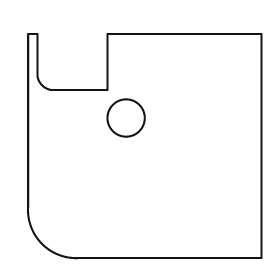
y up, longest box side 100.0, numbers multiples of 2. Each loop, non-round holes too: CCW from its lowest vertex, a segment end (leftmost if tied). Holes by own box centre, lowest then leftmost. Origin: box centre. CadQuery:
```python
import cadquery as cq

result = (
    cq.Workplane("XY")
    .moveTo(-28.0, -48.0)
    .lineTo(50.0, -48.0)
    .lineTo(50.0, 48.0)
    .lineTo(-16.0, 48.0)
    .lineTo(-16.0, 24.0)
    .lineTo(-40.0, 24.0)
    .threePointArc((-44.0, 26.0), (-46.0, 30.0))
    .lineTo(-46.0, 48.0)
    .lineTo(-50.0, 48.0)
    .lineTo(-50.0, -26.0)
    .threePointArc((-44.0, -42.0), (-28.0, -48.0))
    .close()
    .moveTo(-8.0, 12.0)
    .circle(8.0)
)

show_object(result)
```